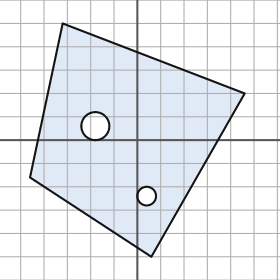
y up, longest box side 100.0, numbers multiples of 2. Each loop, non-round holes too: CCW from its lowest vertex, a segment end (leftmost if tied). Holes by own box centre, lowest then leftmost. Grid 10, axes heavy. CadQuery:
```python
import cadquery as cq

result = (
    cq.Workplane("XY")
    .moveTo(6.0, -50.0)
    .lineTo(46.0, 20.0)
    .lineTo(-32.0, 50.0)
    .lineTo(-46.0, -16.0)
    .close()
    .moveTo(4.0, -24.0)
    .circle(4.0)
    .moveTo(-18.0, 6.0)
    .circle(6.0)
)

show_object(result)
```